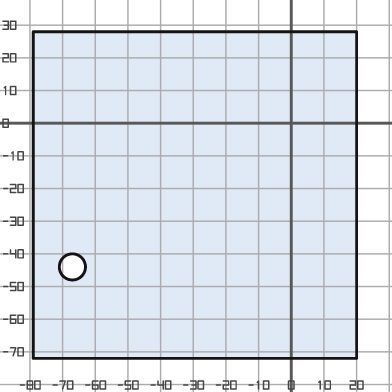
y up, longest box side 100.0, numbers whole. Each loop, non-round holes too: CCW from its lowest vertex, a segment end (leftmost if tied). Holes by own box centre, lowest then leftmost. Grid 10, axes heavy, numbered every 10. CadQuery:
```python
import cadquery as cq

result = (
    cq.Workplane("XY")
    .moveTo(-79.0, -72.0)
    .lineTo(20.0, -72.0)
    .lineTo(20.0, 28.0)
    .lineTo(-79.0, 28.0)
    .close()
    .moveTo(-67.0, -44.0)
    .circle(4.0)
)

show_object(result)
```